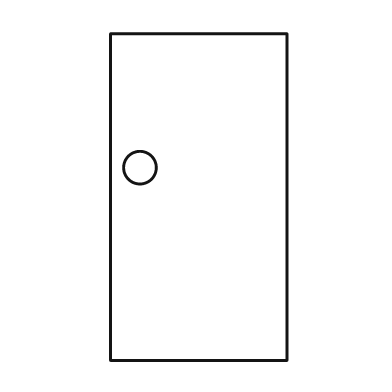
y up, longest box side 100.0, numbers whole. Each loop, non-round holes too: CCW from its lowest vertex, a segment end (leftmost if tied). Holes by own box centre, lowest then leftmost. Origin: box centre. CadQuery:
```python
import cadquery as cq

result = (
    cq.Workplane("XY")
    .moveTo(-27.0, -50.0)
    .lineTo(27.0, -50.0)
    .lineTo(27.0, 50.0)
    .lineTo(-27.0, 50.0)
    .close()
    .moveTo(-18.0, 9.0)
    .circle(5.0)
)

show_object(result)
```